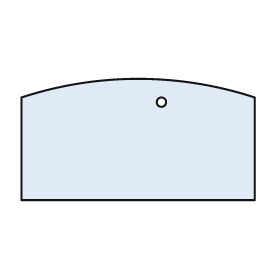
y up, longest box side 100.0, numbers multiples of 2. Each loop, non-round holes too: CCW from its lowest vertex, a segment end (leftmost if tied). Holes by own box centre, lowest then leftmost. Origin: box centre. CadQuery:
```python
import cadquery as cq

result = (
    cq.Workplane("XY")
    .moveTo(-50.0, -26.0)
    .lineTo(50.0, -26.0)
    .lineTo(50.0, 18.0)
    .threePointArc((0.0, 26.0), (-50.0, 18.0))
    .close()
    .moveTo(10.0, 16.0)
    .circle(2.0)
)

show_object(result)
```